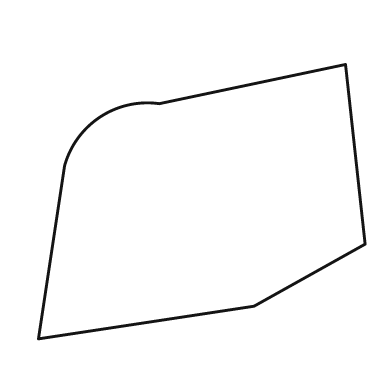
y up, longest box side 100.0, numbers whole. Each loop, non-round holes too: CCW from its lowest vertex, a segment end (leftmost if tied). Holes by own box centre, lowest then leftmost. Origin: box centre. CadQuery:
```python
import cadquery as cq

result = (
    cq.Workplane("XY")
    .moveTo(-50.0, -42.0)
    .lineTo(16.0, -32.0)
    .lineTo(50.0, -13.0)
    .lineTo(44.0, 42.0)
    .lineTo(-13.0, 30.0)
    .threePointArc((-31.0, 26.0), (-42.0, 11.0))
    .close()
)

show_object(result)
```